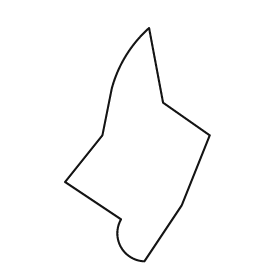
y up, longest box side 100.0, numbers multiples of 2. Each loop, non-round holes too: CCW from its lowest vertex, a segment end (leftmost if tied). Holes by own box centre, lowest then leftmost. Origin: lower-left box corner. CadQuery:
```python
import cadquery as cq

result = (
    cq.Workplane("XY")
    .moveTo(34.0, 0.0)
    .lineTo(50.0, 24.0)
    .lineTo(62.0, 54.0)
    .lineTo(42.0, 68.0)
    .lineTo(36.0, 100.0)
    .threePointArc((26.0, 88.0), (20.0, 74.0))
    .lineTo(16.0, 54.0)
    .lineTo(0.0, 34.0)
    .lineTo(24.0, 18.0)
    .threePointArc((24.0, 6.0), (34.0, 0.0))
    .close()
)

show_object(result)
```